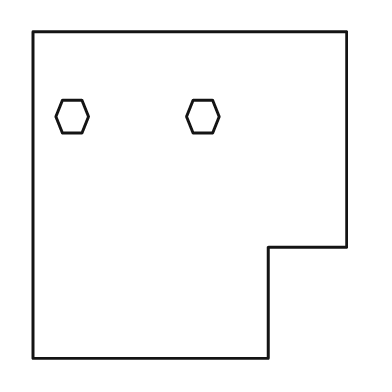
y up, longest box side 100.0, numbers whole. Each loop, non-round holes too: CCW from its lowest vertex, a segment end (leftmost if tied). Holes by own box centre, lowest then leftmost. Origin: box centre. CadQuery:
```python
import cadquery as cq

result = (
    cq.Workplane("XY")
    .moveTo(-48.0, -50.0)
    .lineTo(24.0, -50.0)
    .lineTo(24.0, -16.0)
    .lineTo(48.0, -16.0)
    .lineTo(48.0, 50.0)
    .lineTo(-48.0, 50.0)
    .close()
    .moveTo(-39.0, 19.0)
    .lineTo(-33.0, 19.0)
    .lineTo(-31.0, 24.0)
    .lineTo(-33.0, 29.0)
    .lineTo(-39.0, 29.0)
    .lineTo(-41.0, 24.0)
    .close()
    .moveTo(1.0, 19.0)
    .lineTo(7.0, 19.0)
    .lineTo(9.0, 24.0)
    .lineTo(7.0, 29.0)
    .lineTo(1.0, 29.0)
    .lineTo(-1.0, 24.0)
    .close()
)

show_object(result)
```